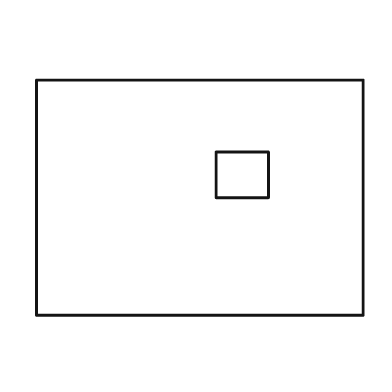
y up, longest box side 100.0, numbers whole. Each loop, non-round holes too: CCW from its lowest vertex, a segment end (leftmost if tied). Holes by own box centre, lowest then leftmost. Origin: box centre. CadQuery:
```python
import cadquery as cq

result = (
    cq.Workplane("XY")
    .moveTo(-50.0, -36.0)
    .lineTo(50.0, -36.0)
    .lineTo(50.0, 36.0)
    .lineTo(-50.0, 36.0)
    .close()
    .moveTo(5.0, 0.0)
    .lineTo(21.0, 0.0)
    .lineTo(21.0, 14.0)
    .lineTo(5.0, 14.0)
    .close()
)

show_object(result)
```